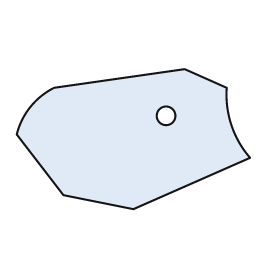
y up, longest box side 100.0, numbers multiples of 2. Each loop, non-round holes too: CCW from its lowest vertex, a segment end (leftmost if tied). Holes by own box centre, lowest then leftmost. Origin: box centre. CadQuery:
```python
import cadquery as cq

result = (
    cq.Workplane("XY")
    .moveTo(0.0, -30.0)
    .lineTo(50.0, -8.0)
    .threePointArc((42.0, 6.0), (40.0, 22.0))
    .lineTo(22.0, 30.0)
    .lineTo(-34.0, 22.0)
    .threePointArc((-44.0, 14.0), (-50.0, 2.0))
    .lineTo(-30.0, -24.0)
    .close()
    .moveTo(14.0, 10.0)
    .circle(4.0)
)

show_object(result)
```